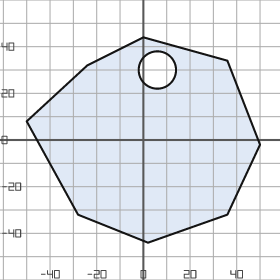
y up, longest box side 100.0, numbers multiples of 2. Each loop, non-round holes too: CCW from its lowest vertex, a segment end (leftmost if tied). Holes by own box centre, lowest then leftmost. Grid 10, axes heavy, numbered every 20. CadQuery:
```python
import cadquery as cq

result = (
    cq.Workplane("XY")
    .moveTo(2.0, -44.0)
    .lineTo(36.0, -32.0)
    .lineTo(50.0, -2.0)
    .lineTo(36.0, 34.0)
    .lineTo(0.0, 44.0)
    .lineTo(-24.0, 32.0)
    .lineTo(-50.0, 8.0)
    .lineTo(-28.0, -32.0)
    .close()
    .moveTo(6.0, 30.0)
    .circle(8.0)
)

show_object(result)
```